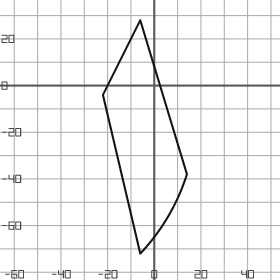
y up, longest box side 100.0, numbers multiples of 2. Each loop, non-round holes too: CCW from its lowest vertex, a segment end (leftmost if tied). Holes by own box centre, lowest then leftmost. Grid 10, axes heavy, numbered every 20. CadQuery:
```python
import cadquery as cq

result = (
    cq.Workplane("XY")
    .moveTo(-6.0, -72.0)
    .threePointArc((6.0, -56.0), (14.0, -38.0))
    .lineTo(-6.0, 28.0)
    .lineTo(-22.0, -4.0)
    .close()
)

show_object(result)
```